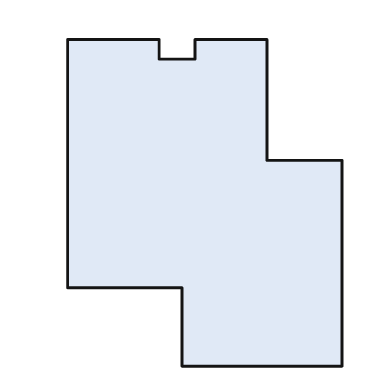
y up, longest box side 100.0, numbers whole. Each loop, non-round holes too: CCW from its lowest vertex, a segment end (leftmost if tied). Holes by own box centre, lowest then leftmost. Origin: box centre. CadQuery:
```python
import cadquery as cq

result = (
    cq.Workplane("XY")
    .moveTo(-7.0, -50.0)
    .lineTo(42.0, -50.0)
    .lineTo(42.0, 13.0)
    .lineTo(19.0, 13.0)
    .lineTo(19.0, 50.0)
    .lineTo(-3.0, 50.0)
    .lineTo(-3.0, 44.0)
    .lineTo(-14.0, 44.0)
    .lineTo(-14.0, 50.0)
    .lineTo(-42.0, 50.0)
    .lineTo(-42.0, -26.0)
    .lineTo(-7.0, -26.0)
    .close()
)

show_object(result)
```